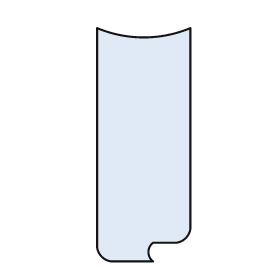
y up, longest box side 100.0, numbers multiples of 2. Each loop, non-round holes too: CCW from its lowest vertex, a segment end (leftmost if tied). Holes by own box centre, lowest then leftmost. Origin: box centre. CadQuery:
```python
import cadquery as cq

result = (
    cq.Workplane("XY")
    .moveTo(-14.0, -50.0)
    .lineTo(4.0, -50.0)
    .threePointArc((2.0, -46.0), (4.0, -42.0))
    .lineTo(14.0, -42.0)
    .threePointArc((18.0, -40.0), (20.0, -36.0))
    .lineTo(20.0, 50.0)
    .threePointArc((0.0, 46.0), (-20.0, 50.0))
    .lineTo(-20.0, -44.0)
    .threePointArc((-18.0, -48.0), (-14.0, -50.0))
    .close()
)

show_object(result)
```